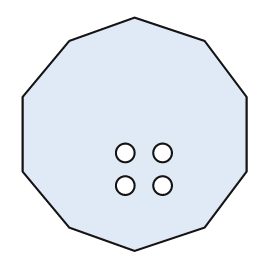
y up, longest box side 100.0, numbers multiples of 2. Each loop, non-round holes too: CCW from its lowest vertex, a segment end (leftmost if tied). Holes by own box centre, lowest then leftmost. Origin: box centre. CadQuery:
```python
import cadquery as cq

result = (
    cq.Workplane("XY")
    .moveTo(0.0, -50.0)
    .lineTo(30.0, -40.0)
    .lineTo(48.0, -16.0)
    .lineTo(48.0, 16.0)
    .lineTo(30.0, 40.0)
    .lineTo(0.0, 50.0)
    .lineTo(-28.0, 40.0)
    .lineTo(-48.0, 16.0)
    .lineTo(-48.0, -16.0)
    .lineTo(-28.0, -40.0)
    .close()
    .moveTo(-4.0, -22.0)
    .circle(4.0)
    .moveTo(12.0, -22.0)
    .circle(4.0)
    .moveTo(-4.0, -8.0)
    .circle(4.0)
    .moveTo(12.0, -8.0)
    .circle(4.0)
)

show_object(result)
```